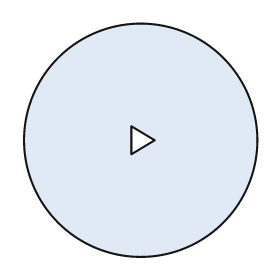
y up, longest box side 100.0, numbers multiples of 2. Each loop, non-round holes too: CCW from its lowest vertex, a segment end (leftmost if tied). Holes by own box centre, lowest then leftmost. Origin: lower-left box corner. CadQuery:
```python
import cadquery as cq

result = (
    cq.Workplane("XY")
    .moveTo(50.0, 50.0)
    .circle(50.0)
    .moveTo(46.0, 44.0)
    .lineTo(56.0, 50.0)
    .lineTo(46.0, 56.0)
    .close()
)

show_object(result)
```